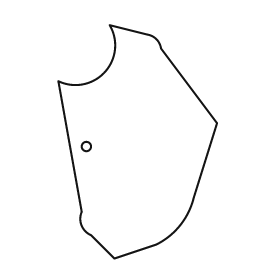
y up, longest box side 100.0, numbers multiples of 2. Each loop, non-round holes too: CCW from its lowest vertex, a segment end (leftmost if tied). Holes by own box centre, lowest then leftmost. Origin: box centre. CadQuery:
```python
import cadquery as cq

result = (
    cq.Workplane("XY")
    .moveTo(-10.0, -50.0)
    .lineTo(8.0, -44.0)
    .threePointArc((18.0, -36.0), (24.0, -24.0))
    .lineTo(34.0, 8.0)
    .lineTo(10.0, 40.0)
    .threePointArc((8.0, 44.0), (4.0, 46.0))
    .lineTo(-12.0, 50.0)
    .threePointArc((-14.0, 30.0), (-34.0, 26.0))
    .lineTo(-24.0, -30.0)
    .threePointArc((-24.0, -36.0), (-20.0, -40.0))
    .close()
    .moveTo(-22.0, -2.0)
    .circle(2.0)
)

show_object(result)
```